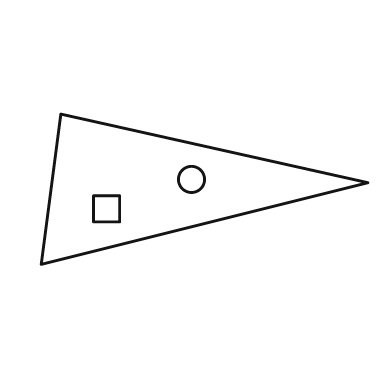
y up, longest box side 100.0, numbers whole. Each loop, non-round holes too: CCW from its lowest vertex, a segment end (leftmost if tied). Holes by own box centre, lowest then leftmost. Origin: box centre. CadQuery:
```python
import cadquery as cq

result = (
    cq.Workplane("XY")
    .moveTo(-50.0, -23.0)
    .lineTo(50.0, 2.0)
    .lineTo(-44.0, 23.0)
    .close()
    .moveTo(-34.0, -10.0)
    .lineTo(-26.0, -10.0)
    .lineTo(-26.0, -2.0)
    .lineTo(-34.0, -2.0)
    .close()
    .moveTo(-4.0, 3.0)
    .circle(4.0)
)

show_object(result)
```